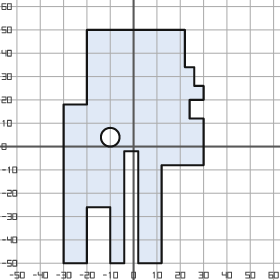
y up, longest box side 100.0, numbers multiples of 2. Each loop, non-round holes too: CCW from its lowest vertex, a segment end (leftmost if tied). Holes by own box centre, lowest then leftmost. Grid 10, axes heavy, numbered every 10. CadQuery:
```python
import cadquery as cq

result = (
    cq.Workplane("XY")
    .moveTo(-30.0, -50.0)
    .lineTo(-20.0, -50.0)
    .lineTo(-20.0, -26.0)
    .lineTo(-10.0, -26.0)
    .lineTo(-10.0, -50.0)
    .lineTo(-4.0, -50.0)
    .lineTo(-4.0, -2.0)
    .lineTo(2.0, -2.0)
    .lineTo(2.0, -50.0)
    .lineTo(12.0, -50.0)
    .lineTo(12.0, -8.0)
    .lineTo(30.0, -8.0)
    .lineTo(30.0, 12.0)
    .lineTo(24.0, 12.0)
    .lineTo(24.0, 20.0)
    .lineTo(30.0, 20.0)
    .lineTo(30.0, 26.0)
    .lineTo(26.0, 26.0)
    .lineTo(26.0, 34.0)
    .lineTo(22.0, 34.0)
    .lineTo(22.0, 50.0)
    .lineTo(-20.0, 50.0)
    .lineTo(-20.0, 18.0)
    .lineTo(-30.0, 18.0)
    .close()
    .moveTo(-10.0, 4.0)
    .circle(4.0)
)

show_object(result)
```